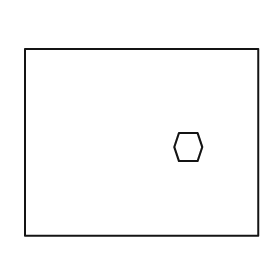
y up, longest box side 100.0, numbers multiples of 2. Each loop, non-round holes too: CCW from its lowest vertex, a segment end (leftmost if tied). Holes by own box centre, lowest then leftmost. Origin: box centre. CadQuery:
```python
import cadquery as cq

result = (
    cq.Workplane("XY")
    .moveTo(-50.0, -40.0)
    .lineTo(50.0, -40.0)
    .lineTo(50.0, 40.0)
    .lineTo(-50.0, 40.0)
    .close()
    .moveTo(16.0, -8.0)
    .lineTo(24.0, -8.0)
    .lineTo(26.0, -2.0)
    .lineTo(24.0, 4.0)
    .lineTo(16.0, 4.0)
    .lineTo(14.0, -2.0)
    .close()
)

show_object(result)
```